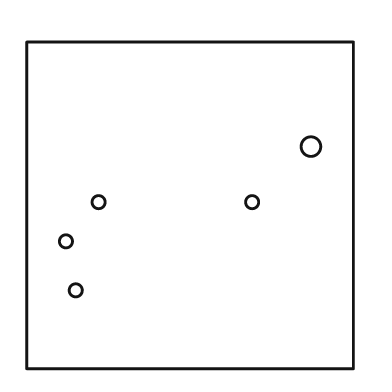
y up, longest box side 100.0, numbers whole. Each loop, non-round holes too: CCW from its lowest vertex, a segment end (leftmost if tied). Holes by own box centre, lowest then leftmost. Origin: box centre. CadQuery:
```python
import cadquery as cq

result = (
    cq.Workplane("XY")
    .moveTo(-50.0, -50.0)
    .lineTo(50.0, -50.0)
    .lineTo(50.0, 50.0)
    .lineTo(-50.0, 50.0)
    .close()
    .moveTo(-35.0, -26.0)
    .circle(2.0)
    .moveTo(-38.0, -11.0)
    .circle(2.0)
    .moveTo(-28.0, 1.0)
    .circle(2.0)
    .moveTo(19.0, 1.0)
    .circle(2.0)
    .moveTo(37.0, 18.0)
    .circle(3.0)
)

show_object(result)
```